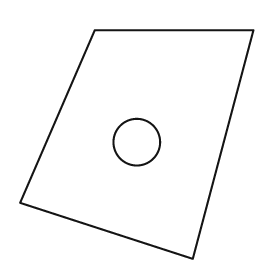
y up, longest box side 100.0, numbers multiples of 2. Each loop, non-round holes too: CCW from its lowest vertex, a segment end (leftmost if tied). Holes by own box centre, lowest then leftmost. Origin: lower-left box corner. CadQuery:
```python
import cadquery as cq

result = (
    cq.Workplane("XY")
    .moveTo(74.0, 0.0)
    .lineTo(100.0, 98.0)
    .lineTo(32.0, 98.0)
    .lineTo(0.0, 24.0)
    .close()
    .moveTo(50.0, 50.0)
    .circle(10.0)
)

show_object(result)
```